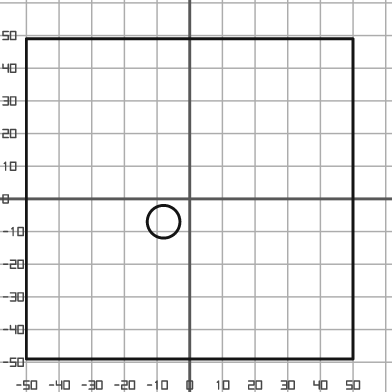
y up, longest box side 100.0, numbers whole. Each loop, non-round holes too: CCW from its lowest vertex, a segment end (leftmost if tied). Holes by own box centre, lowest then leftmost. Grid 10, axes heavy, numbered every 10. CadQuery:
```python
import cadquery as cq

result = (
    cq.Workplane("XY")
    .moveTo(-50.0, -49.0)
    .lineTo(50.0, -49.0)
    .lineTo(50.0, 49.0)
    .lineTo(-50.0, 49.0)
    .close()
    .moveTo(-8.0, -7.0)
    .circle(5.0)
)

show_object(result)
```